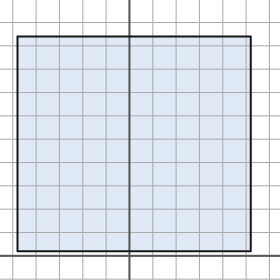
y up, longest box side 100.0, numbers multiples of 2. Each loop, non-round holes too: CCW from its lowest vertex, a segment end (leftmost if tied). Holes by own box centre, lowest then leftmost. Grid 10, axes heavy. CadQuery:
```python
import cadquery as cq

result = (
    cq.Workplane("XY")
    .moveTo(-48.0, 2.0)
    .lineTo(52.0, 2.0)
    .lineTo(52.0, 94.0)
    .lineTo(-48.0, 94.0)
    .close()
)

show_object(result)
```